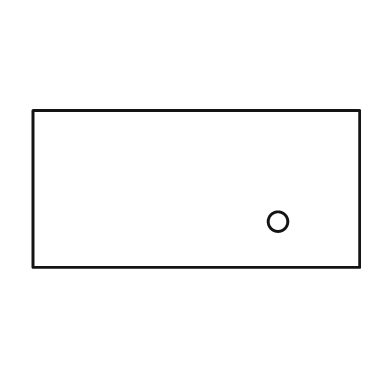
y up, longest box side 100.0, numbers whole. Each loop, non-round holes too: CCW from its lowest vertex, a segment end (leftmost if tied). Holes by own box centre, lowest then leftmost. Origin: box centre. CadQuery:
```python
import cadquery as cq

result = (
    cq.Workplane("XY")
    .moveTo(-50.0, -24.0)
    .lineTo(50.0, -24.0)
    .lineTo(50.0, 24.0)
    .lineTo(-50.0, 24.0)
    .close()
    .moveTo(25.0, -10.0)
    .circle(3.0)
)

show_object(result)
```